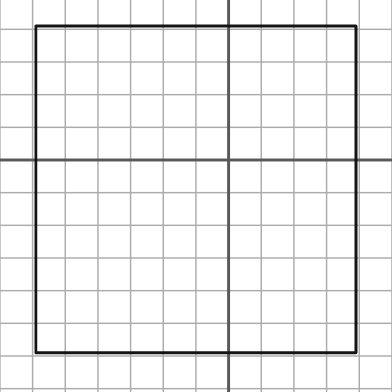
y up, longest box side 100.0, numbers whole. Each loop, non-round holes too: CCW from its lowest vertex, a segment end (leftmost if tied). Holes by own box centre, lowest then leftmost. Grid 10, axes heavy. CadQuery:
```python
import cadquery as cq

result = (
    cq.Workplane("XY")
    .moveTo(-59.0, -59.0)
    .lineTo(39.0, -59.0)
    .lineTo(39.0, 41.0)
    .lineTo(-59.0, 41.0)
    .close()
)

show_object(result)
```